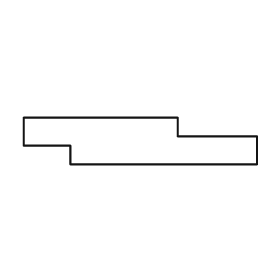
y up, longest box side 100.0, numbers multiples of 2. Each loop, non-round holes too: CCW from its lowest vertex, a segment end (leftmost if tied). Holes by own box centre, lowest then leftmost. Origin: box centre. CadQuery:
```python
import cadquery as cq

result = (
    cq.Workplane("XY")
    .moveTo(-30.0, -10.0)
    .lineTo(50.0, -10.0)
    .lineTo(50.0, 2.0)
    .lineTo(16.0, 2.0)
    .lineTo(16.0, 10.0)
    .lineTo(-50.0, 10.0)
    .lineTo(-50.0, -2.0)
    .lineTo(-30.0, -2.0)
    .close()
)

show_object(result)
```